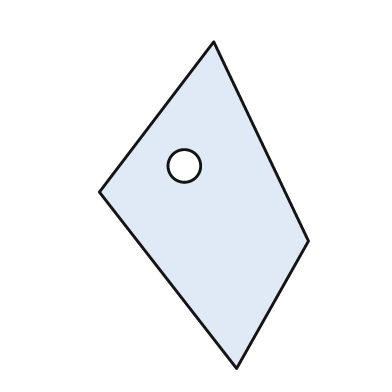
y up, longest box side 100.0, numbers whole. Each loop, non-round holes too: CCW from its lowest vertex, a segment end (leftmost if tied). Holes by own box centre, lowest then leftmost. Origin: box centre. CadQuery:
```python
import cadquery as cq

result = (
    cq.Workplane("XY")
    .moveTo(10.0, -50.0)
    .lineTo(32.0, -11.0)
    .lineTo(3.0, 50.0)
    .lineTo(-32.0, 4.0)
    .close()
    .moveTo(-6.0, 12.0)
    .circle(5.0)
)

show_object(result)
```